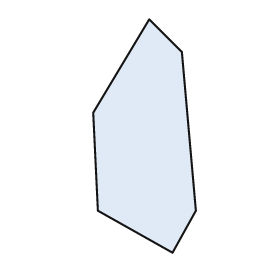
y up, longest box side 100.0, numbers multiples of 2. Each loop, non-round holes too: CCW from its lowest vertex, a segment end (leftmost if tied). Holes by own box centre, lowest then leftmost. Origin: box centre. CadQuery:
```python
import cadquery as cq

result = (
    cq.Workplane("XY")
    .moveTo(12.0, -50.0)
    .lineTo(22.0, -32.0)
    .lineTo(16.0, 36.0)
    .lineTo(2.0, 50.0)
    .lineTo(-22.0, 10.0)
    .lineTo(-20.0, -32.0)
    .close()
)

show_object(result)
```